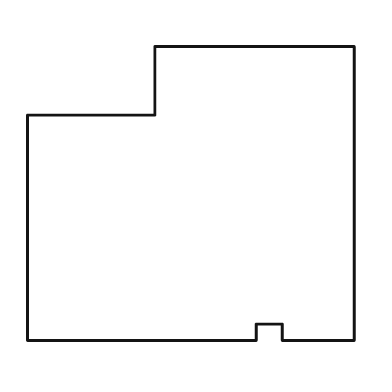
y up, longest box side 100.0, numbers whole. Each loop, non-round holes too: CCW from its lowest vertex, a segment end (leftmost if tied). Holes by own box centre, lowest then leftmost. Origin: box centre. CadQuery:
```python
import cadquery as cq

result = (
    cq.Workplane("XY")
    .moveTo(-50.0, -45.0)
    .lineTo(20.0, -45.0)
    .lineTo(20.0, -40.0)
    .lineTo(28.0, -40.0)
    .lineTo(28.0, -45.0)
    .lineTo(50.0, -45.0)
    .lineTo(50.0, 45.0)
    .lineTo(-11.0, 45.0)
    .lineTo(-11.0, 24.0)
    .lineTo(-50.0, 24.0)
    .close()
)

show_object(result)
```